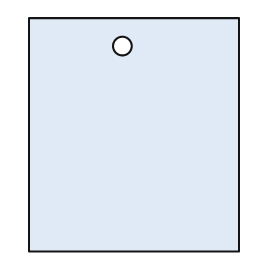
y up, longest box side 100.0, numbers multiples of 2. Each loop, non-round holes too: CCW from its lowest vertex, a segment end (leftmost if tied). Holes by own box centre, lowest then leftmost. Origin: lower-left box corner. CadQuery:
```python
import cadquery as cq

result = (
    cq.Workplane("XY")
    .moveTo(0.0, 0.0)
    .lineTo(90.0, 0.0)
    .lineTo(90.0, 100.0)
    .lineTo(0.0, 100.0)
    .close()
    .moveTo(40.0, 88.0)
    .circle(4.0)
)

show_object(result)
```